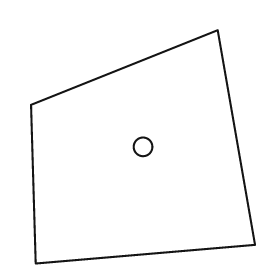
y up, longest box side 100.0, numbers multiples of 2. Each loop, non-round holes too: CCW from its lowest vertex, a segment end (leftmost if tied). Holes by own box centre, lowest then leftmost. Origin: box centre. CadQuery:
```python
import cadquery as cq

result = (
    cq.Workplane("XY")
    .moveTo(-46.0, -50.0)
    .lineTo(48.0, -42.0)
    .lineTo(32.0, 50.0)
    .lineTo(-48.0, 18.0)
    .close()
    .moveTo(0.0, 0.0)
    .circle(4.0)
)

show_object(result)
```